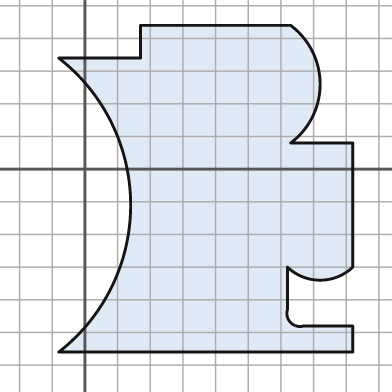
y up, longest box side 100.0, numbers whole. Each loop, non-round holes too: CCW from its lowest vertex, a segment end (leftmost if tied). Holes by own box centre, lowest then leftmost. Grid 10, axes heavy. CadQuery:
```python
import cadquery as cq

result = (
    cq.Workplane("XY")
    .moveTo(-8.0, -56.0)
    .lineTo(82.0, -56.0)
    .lineTo(82.0, -48.0)
    .lineTo(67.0, -48.0)
    .threePointArc((63.0, -47.0), (62.0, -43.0))
    .lineTo(62.0, -30.0)
    .threePointArc((72.0, -34.0), (82.0, -30.0))
    .lineTo(82.0, 8.0)
    .lineTo(63.0, 8.0)
    .threePointArc((72.0, 26.0), (63.0, 44.0))
    .lineTo(17.0, 44.0)
    .lineTo(17.0, 34.0)
    .lineTo(-8.0, 34.0)
    .threePointArc((14.0, -11.0), (-8.0, -56.0))
    .close()
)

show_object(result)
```